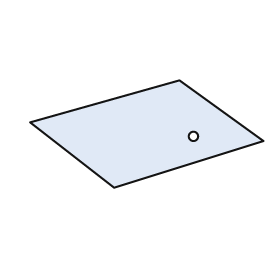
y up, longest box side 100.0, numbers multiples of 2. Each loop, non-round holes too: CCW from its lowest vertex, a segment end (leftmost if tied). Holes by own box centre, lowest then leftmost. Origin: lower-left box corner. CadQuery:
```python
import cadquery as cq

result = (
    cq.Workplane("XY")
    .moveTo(36.0, 0.0)
    .lineTo(100.0, 20.0)
    .lineTo(64.0, 46.0)
    .lineTo(0.0, 28.0)
    .close()
    .moveTo(70.0, 22.0)
    .circle(2.0)
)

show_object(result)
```